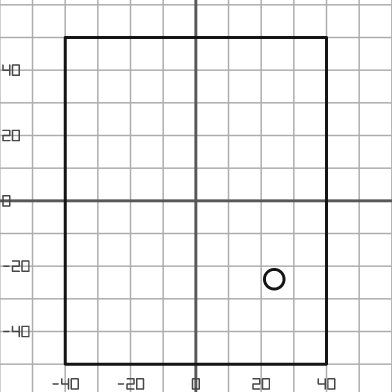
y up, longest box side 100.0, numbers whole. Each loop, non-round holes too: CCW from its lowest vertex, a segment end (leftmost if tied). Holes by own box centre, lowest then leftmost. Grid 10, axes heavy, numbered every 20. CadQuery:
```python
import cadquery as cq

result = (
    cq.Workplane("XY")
    .moveTo(-40.0, -50.0)
    .lineTo(40.0, -50.0)
    .lineTo(40.0, 50.0)
    .lineTo(-40.0, 50.0)
    .close()
    .moveTo(24.0, -24.0)
    .circle(3.0)
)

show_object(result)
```